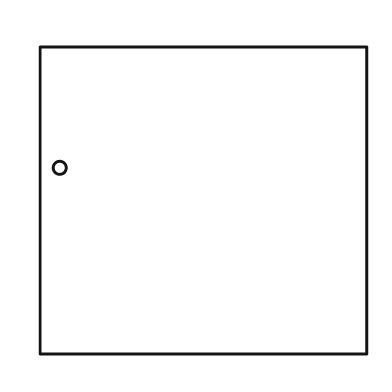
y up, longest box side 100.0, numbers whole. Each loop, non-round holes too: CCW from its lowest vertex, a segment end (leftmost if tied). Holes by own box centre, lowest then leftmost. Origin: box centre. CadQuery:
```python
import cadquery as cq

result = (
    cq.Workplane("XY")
    .moveTo(-50.0, -47.0)
    .lineTo(50.0, -47.0)
    .lineTo(50.0, 47.0)
    .lineTo(-50.0, 47.0)
    .close()
    .moveTo(-44.0, 10.0)
    .circle(2.0)
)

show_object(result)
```